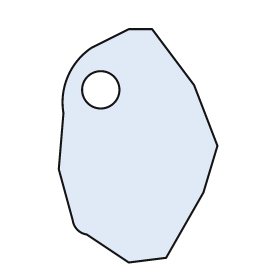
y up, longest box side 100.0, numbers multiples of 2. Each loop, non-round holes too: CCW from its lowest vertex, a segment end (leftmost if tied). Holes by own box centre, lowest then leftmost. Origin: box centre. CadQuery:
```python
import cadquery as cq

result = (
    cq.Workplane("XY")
    .moveTo(-4.0, -50.0)
    .lineTo(12.0, -48.0)
    .lineTo(28.0, -20.0)
    .lineTo(34.0, 0.0)
    .lineTo(24.0, 26.0)
    .lineTo(6.0, 50.0)
    .lineTo(-4.0, 50.0)
    .lineTo(-20.0, 42.0)
    .threePointArc((-30.0, 30.0), (-32.0, 14.0))
    .lineTo(-34.0, -10.0)
    .lineTo(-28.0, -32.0)
    .threePointArc((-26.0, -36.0), (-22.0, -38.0))
    .close()
    .moveTo(-16.0, 24.0)
    .circle(8.0)
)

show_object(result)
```